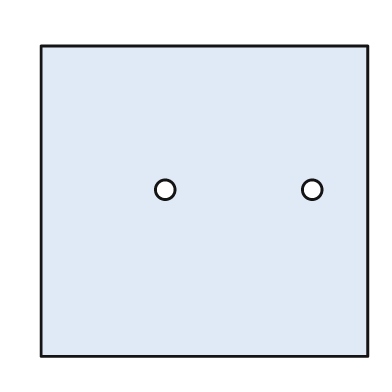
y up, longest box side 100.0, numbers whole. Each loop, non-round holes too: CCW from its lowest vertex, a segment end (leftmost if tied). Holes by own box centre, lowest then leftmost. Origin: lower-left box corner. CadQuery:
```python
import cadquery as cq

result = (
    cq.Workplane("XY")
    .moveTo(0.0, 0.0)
    .lineTo(100.0, 0.0)
    .lineTo(100.0, 95.0)
    .lineTo(0.0, 95.0)
    .close()
    .moveTo(38.0, 51.0)
    .circle(3.0)
    .moveTo(83.0, 51.0)
    .circle(3.0)
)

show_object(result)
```